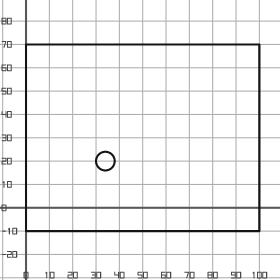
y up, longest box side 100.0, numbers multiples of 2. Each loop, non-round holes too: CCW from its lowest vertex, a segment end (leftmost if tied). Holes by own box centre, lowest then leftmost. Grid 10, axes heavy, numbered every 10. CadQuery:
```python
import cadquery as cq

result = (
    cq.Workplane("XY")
    .moveTo(0.0, -10.0)
    .lineTo(100.0, -10.0)
    .lineTo(100.0, 70.0)
    .lineTo(0.0, 70.0)
    .close()
    .moveTo(34.0, 20.0)
    .circle(4.0)
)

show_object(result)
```